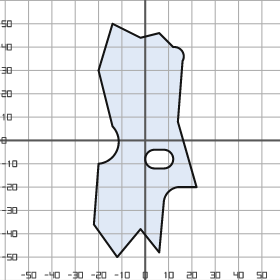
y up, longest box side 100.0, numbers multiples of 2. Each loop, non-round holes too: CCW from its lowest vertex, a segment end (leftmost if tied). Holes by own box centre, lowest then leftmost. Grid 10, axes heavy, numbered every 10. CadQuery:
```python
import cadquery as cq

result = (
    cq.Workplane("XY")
    .moveTo(-12.0, -50.0)
    .lineTo(-2.0, -38.0)
    .lineTo(6.0, -48.0)
    .lineTo(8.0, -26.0)
    .threePointArc((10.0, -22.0), (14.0, -20.0))
    .lineTo(22.0, -20.0)
    .lineTo(14.0, 8.0)
    .lineTo(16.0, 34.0)
    .threePointArc((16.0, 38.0), (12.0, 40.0))
    .lineTo(6.0, 46.0)
    .lineTo(-2.0, 44.0)
    .lineTo(-14.0, 50.0)
    .lineTo(-20.0, 30.0)
    .lineTo(-14.0, 6.0)
    .threePointArc((-12.0, -4.0), (-20.0, -10.0))
    .lineTo(-22.0, -36.0)
    .close()
    .moveTo(4.0, -12.0)
    .lineTo(8.0, -12.0)
    .threePointArc((12.0, -8.0), (8.0, -4.0))
    .lineTo(4.0, -4.0)
    .threePointArc((0.0, -8.0), (4.0, -12.0))
    .close()
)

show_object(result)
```